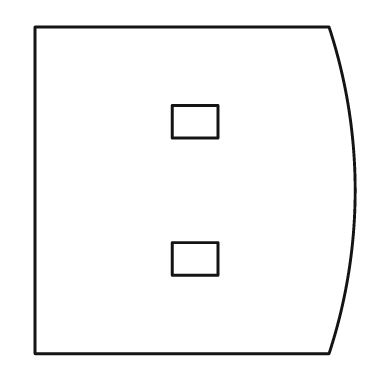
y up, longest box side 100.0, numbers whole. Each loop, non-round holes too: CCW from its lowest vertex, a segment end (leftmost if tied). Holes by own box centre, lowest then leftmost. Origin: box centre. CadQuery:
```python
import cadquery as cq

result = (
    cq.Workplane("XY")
    .moveTo(-49.0, -50.0)
    .lineTo(41.0, -50.0)
    .threePointArc((49.0, 0.0), (41.0, 50.0))
    .lineTo(-49.0, 50.0)
    .close()
    .moveTo(-7.0, -26.0)
    .lineTo(7.0, -26.0)
    .lineTo(7.0, -16.0)
    .lineTo(-7.0, -16.0)
    .close()
    .moveTo(-7.0, 16.0)
    .lineTo(7.0, 16.0)
    .lineTo(7.0, 26.0)
    .lineTo(-7.0, 26.0)
    .close()
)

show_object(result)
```